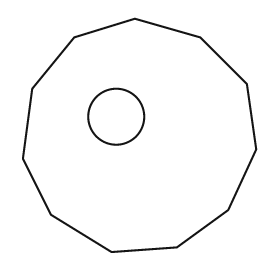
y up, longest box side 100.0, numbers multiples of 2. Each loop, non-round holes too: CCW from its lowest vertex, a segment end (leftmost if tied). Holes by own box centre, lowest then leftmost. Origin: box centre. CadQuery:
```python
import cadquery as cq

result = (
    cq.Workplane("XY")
    .moveTo(-12.0, -50.0)
    .lineTo(16.0, -48.0)
    .lineTo(38.0, -32.0)
    .lineTo(50.0, -6.0)
    .lineTo(46.0, 22.0)
    .lineTo(26.0, 42.0)
    .lineTo(-2.0, 50.0)
    .lineTo(-28.0, 42.0)
    .lineTo(-46.0, 20.0)
    .lineTo(-50.0, -10.0)
    .lineTo(-38.0, -34.0)
    .close()
    .moveTo(-10.0, 8.0)
    .circle(12.0)
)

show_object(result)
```